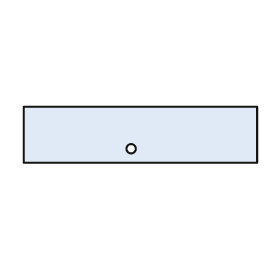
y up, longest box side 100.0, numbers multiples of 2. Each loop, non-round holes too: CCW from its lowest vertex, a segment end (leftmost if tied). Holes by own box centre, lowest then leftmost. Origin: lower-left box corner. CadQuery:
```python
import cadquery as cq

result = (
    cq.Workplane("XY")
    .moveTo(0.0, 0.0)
    .lineTo(100.0, 0.0)
    .lineTo(100.0, 24.0)
    .lineTo(0.0, 24.0)
    .close()
    .moveTo(46.0, 6.0)
    .circle(2.0)
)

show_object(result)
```